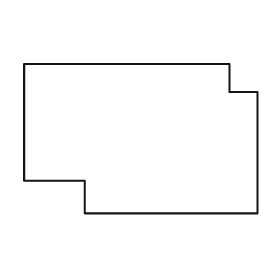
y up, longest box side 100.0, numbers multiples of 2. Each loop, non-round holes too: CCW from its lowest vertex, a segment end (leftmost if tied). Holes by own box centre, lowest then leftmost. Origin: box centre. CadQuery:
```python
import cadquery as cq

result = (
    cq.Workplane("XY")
    .moveTo(-24.0, -32.0)
    .lineTo(50.0, -32.0)
    .lineTo(50.0, 20.0)
    .lineTo(38.0, 20.0)
    .lineTo(38.0, 32.0)
    .lineTo(-50.0, 32.0)
    .lineTo(-50.0, -18.0)
    .lineTo(-24.0, -18.0)
    .close()
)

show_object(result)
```